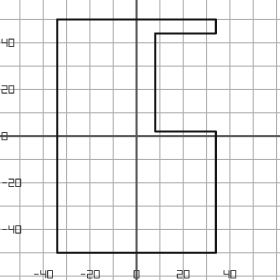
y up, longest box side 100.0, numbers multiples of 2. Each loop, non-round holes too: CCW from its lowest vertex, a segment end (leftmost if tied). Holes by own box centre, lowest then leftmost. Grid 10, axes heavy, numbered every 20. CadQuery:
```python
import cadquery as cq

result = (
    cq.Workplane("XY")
    .moveTo(-34.0, -50.0)
    .lineTo(34.0, -50.0)
    .lineTo(34.0, 2.0)
    .lineTo(8.0, 2.0)
    .lineTo(8.0, 44.0)
    .lineTo(34.0, 44.0)
    .lineTo(34.0, 50.0)
    .lineTo(-34.0, 50.0)
    .close()
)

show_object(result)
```